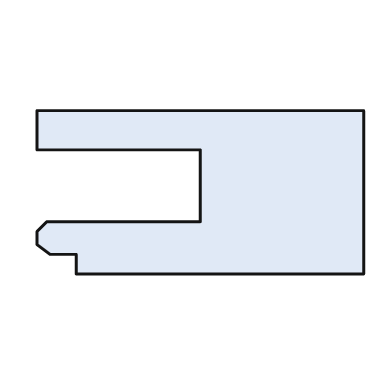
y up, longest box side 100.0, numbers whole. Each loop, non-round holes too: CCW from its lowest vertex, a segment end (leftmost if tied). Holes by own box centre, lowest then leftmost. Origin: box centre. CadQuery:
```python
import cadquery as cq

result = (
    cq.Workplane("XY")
    .moveTo(-38.0, -25.0)
    .lineTo(50.0, -25.0)
    .lineTo(50.0, 25.0)
    .lineTo(-50.0, 25.0)
    .lineTo(-50.0, 13.0)
    .lineTo(0.0, 13.0)
    .lineTo(0.0, -9.0)
    .lineTo(-47.0, -9.0)
    .lineTo(-50.0, -12.0)
    .lineTo(-50.0, -16.0)
    .lineTo(-46.0, -19.0)
    .lineTo(-38.0, -19.0)
    .close()
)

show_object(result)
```